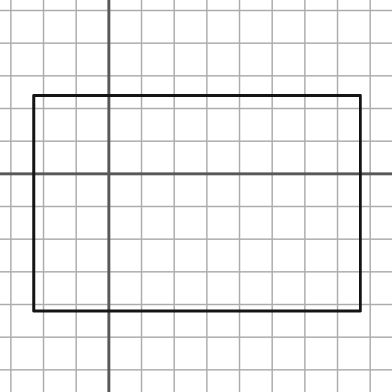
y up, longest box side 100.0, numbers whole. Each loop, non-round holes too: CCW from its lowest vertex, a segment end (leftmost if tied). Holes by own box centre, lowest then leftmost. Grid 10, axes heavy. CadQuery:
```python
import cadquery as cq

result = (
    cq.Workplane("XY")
    .moveTo(-23.0, -42.0)
    .lineTo(77.0, -42.0)
    .lineTo(77.0, 24.0)
    .lineTo(-23.0, 24.0)
    .close()
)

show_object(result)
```